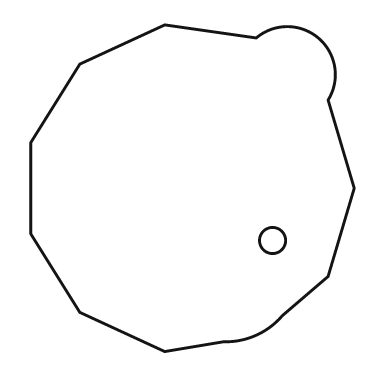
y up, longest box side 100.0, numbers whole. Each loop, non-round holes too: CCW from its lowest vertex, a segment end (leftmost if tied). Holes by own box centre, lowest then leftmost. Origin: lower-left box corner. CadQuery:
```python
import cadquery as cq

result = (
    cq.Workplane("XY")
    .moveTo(41.0, 0.0)
    .lineTo(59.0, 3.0)
    .threePointArc((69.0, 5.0), (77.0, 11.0))
    .lineTo(91.0, 23.0)
    .lineTo(99.0, 50.0)
    .lineTo(91.0, 77.0)
    .threePointArc((88.0, 96.0), (69.0, 96.0))
    .lineTo(41.0, 100.0)
    .lineTo(15.0, 88.0)
    .lineTo(0.0, 64.0)
    .lineTo(0.0, 36.0)
    .lineTo(15.0, 12.0)
    .close()
    .moveTo(74.0, 34.0)
    .circle(4.0)
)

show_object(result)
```